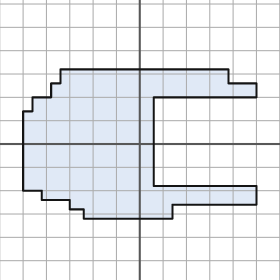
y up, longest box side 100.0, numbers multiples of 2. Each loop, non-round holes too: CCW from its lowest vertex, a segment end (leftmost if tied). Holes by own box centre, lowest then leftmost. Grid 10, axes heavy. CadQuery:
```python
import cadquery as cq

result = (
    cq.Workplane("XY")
    .moveTo(-24.0, -32.0)
    .lineTo(14.0, -32.0)
    .lineTo(14.0, -26.0)
    .lineTo(50.0, -26.0)
    .lineTo(50.0, -18.0)
    .lineTo(6.0, -18.0)
    .lineTo(6.0, 20.0)
    .lineTo(50.0, 20.0)
    .lineTo(50.0, 26.0)
    .lineTo(38.0, 26.0)
    .lineTo(38.0, 32.0)
    .lineTo(-34.0, 32.0)
    .lineTo(-34.0, 26.0)
    .lineTo(-38.0, 26.0)
    .lineTo(-38.0, 20.0)
    .lineTo(-46.0, 20.0)
    .lineTo(-46.0, 14.0)
    .lineTo(-50.0, 14.0)
    .lineTo(-50.0, -20.0)
    .lineTo(-42.0, -20.0)
    .lineTo(-42.0, -24.0)
    .lineTo(-30.0, -24.0)
    .lineTo(-30.0, -28.0)
    .lineTo(-24.0, -28.0)
    .close()
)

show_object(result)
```